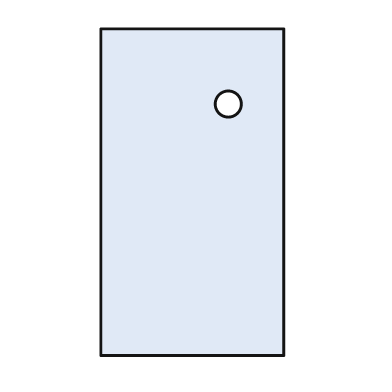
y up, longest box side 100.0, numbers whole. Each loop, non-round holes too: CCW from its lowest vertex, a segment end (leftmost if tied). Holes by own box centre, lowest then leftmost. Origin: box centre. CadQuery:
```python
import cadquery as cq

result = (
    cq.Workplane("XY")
    .moveTo(-28.0, -50.0)
    .lineTo(28.0, -50.0)
    .lineTo(28.0, 50.0)
    .lineTo(-28.0, 50.0)
    .close()
    .moveTo(11.0, 27.0)
    .circle(4.0)
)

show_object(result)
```